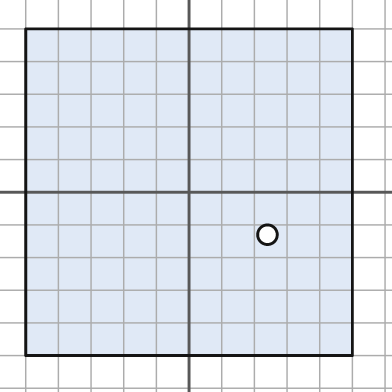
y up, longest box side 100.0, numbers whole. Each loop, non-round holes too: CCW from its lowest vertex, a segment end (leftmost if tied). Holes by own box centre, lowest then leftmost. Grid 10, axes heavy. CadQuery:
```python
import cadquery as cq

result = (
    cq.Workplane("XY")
    .moveTo(-50.0, -50.0)
    .lineTo(50.0, -50.0)
    .lineTo(50.0, 50.0)
    .lineTo(-50.0, 50.0)
    .close()
    .moveTo(24.0, -13.0)
    .circle(3.0)
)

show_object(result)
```